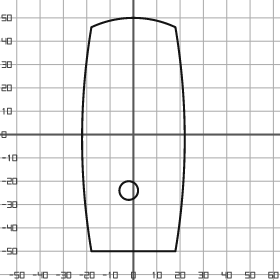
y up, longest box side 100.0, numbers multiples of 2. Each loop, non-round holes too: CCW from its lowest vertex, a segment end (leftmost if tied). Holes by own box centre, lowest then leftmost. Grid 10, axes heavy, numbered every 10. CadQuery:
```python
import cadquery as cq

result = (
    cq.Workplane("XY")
    .moveTo(-18.0, -50.0)
    .lineTo(18.0, -50.0)
    .threePointArc((22.0, -2.0), (18.0, 46.0))
    .threePointArc((0.0, 50.0), (-18.0, 46.0))
    .threePointArc((-22.0, -2.0), (-18.0, -50.0))
    .close()
    .moveTo(-2.0, -24.0)
    .circle(4.0)
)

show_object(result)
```